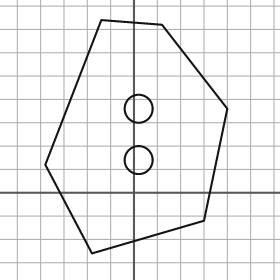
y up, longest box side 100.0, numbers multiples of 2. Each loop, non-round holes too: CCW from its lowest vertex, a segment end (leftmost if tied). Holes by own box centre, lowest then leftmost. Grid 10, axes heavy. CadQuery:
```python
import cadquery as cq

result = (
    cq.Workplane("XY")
    .moveTo(-18.0, -26.0)
    .lineTo(30.0, -12.0)
    .lineTo(40.0, 36.0)
    .lineTo(12.0, 72.0)
    .lineTo(-14.0, 74.0)
    .lineTo(-38.0, 12.0)
    .close()
    .moveTo(2.0, 14.0)
    .circle(6.0)
    .moveTo(2.0, 36.0)
    .circle(6.0)
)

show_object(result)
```